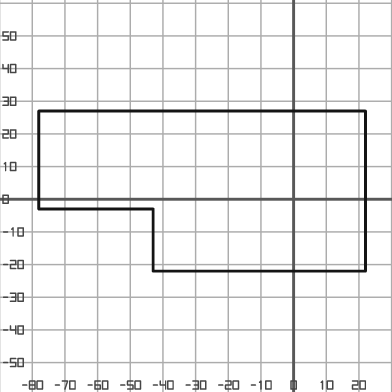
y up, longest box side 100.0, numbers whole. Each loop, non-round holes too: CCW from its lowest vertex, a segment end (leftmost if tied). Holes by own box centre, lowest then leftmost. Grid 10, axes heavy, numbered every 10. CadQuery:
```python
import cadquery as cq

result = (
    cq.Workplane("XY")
    .moveTo(-43.0, -22.0)
    .lineTo(22.0, -22.0)
    .lineTo(22.0, 27.0)
    .lineTo(-78.0, 27.0)
    .lineTo(-78.0, -3.0)
    .lineTo(-43.0, -3.0)
    .close()
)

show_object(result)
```